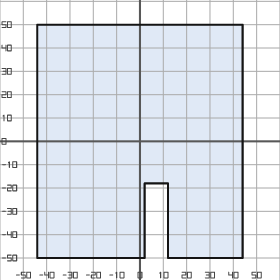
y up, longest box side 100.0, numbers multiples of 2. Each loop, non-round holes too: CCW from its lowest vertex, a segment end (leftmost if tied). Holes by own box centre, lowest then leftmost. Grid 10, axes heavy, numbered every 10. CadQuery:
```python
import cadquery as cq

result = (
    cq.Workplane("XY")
    .moveTo(-44.0, -50.0)
    .lineTo(2.0, -50.0)
    .lineTo(2.0, -18.0)
    .lineTo(12.0, -18.0)
    .lineTo(12.0, -50.0)
    .lineTo(44.0, -50.0)
    .lineTo(44.0, 50.0)
    .lineTo(-44.0, 50.0)
    .close()
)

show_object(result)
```